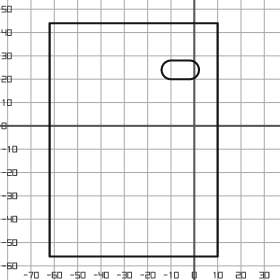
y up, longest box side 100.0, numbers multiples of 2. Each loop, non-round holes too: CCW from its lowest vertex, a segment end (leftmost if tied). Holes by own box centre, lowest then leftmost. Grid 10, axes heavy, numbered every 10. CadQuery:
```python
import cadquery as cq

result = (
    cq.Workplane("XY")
    .moveTo(-62.0, -56.0)
    .lineTo(10.0, -56.0)
    .lineTo(10.0, 44.0)
    .lineTo(-62.0, 44.0)
    .close()
    .moveTo(-10.0, 20.0)
    .lineTo(-2.0, 20.0)
    .threePointArc((2.0, 24.0), (-2.0, 28.0))
    .lineTo(-10.0, 28.0)
    .threePointArc((-14.0, 24.0), (-10.0, 20.0))
    .close()
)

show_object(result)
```